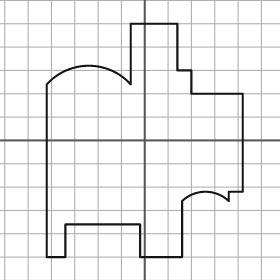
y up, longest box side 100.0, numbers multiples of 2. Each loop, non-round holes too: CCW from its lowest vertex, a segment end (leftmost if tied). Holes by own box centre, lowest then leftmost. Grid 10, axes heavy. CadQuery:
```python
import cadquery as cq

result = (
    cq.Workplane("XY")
    .moveTo(-42.0, -50.0)
    .lineTo(-34.0, -50.0)
    .lineTo(-34.0, -36.0)
    .lineTo(-2.0, -36.0)
    .lineTo(-2.0, -50.0)
    .lineTo(16.0, -50.0)
    .lineTo(16.0, -26.0)
    .threePointArc((26.0, -22.0), (36.0, -26.0))
    .lineTo(36.0, -22.0)
    .lineTo(42.0, -22.0)
    .lineTo(42.0, 20.0)
    .lineTo(20.0, 20.0)
    .lineTo(20.0, 30.0)
    .lineTo(14.0, 30.0)
    .lineTo(14.0, 50.0)
    .lineTo(-6.0, 50.0)
    .lineTo(-6.0, 24.0)
    .threePointArc((-24.0, 32.0), (-42.0, 24.0))
    .close()
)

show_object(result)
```